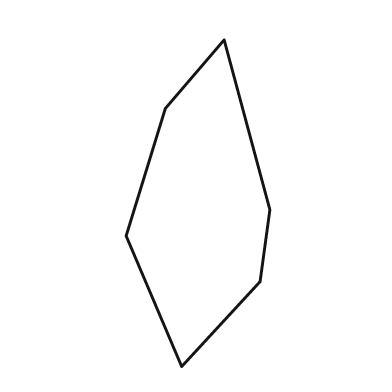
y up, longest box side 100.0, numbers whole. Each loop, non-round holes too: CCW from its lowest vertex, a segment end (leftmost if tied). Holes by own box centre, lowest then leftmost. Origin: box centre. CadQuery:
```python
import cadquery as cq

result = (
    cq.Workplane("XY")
    .moveTo(-5.0, -50.0)
    .lineTo(19.0, -24.0)
    .lineTo(22.0, -2.0)
    .lineTo(8.0, 50.0)
    .lineTo(-10.0, 29.0)
    .lineTo(-22.0, -10.0)
    .close()
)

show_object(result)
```